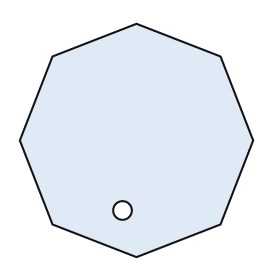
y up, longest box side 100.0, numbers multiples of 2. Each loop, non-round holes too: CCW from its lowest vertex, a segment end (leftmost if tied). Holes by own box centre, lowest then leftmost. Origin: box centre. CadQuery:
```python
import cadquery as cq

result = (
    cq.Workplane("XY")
    .moveTo(0.0, -50.0)
    .lineTo(36.0, -36.0)
    .lineTo(50.0, 0.0)
    .lineTo(36.0, 36.0)
    .lineTo(0.0, 50.0)
    .lineTo(-36.0, 36.0)
    .lineTo(-50.0, 0.0)
    .lineTo(-36.0, -36.0)
    .close()
    .moveTo(-6.0, -30.0)
    .circle(4.0)
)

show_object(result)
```